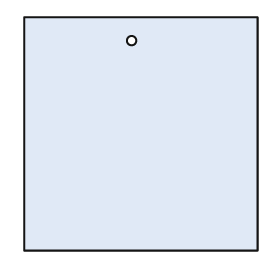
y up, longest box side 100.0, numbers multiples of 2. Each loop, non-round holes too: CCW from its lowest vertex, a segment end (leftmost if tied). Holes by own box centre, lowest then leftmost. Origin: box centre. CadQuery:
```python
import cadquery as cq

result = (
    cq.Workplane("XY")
    .moveTo(-50.0, -50.0)
    .lineTo(50.0, -50.0)
    .lineTo(50.0, 50.0)
    .lineTo(-50.0, 50.0)
    .close()
    .moveTo(-4.0, 40.0)
    .circle(2.0)
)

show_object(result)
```